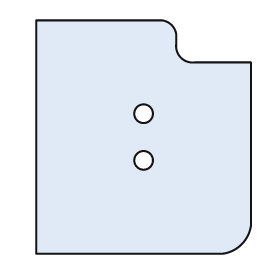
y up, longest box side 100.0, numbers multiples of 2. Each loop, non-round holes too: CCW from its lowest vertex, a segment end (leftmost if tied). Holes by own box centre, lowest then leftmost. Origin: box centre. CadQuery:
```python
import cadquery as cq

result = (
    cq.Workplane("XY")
    .moveTo(-46.0, -50.0)
    .lineTo(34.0, -50.0)
    .threePointArc((42.0, -46.0), (46.0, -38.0))
    .lineTo(46.0, 32.0)
    .lineTo(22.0, 32.0)
    .threePointArc((16.0, 34.0), (14.0, 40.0))
    .lineTo(14.0, 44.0)
    .threePointArc((12.0, 48.0), (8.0, 50.0))
    .lineTo(-46.0, 50.0)
    .close()
    .moveTo(0.0, -10.0)
    .circle(4.0)
    .moveTo(0.0, 10.0)
    .circle(4.0)
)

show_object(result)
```